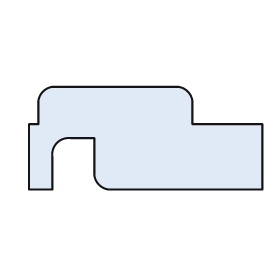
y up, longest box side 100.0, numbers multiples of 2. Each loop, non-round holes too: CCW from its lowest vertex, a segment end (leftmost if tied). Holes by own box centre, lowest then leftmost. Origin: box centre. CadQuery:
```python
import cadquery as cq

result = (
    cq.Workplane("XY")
    .moveTo(-50.0, -22.0)
    .lineTo(-40.0, -22.0)
    .lineTo(-40.0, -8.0)
    .threePointArc((-38.0, -2.0), (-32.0, 0.0))
    .lineTo(-22.0, 0.0)
    .lineTo(-22.0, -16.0)
    .threePointArc((-20.0, -20.0), (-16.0, -22.0))
    .lineTo(50.0, -22.0)
    .lineTo(50.0, 6.0)
    .lineTo(20.0, 6.0)
    .lineTo(20.0, 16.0)
    .threePointArc((18.0, 20.0), (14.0, 22.0))
    .lineTo(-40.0, 22.0)
    .threePointArc((-44.0, 20.0), (-46.0, 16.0))
    .lineTo(-46.0, 6.0)
    .lineTo(-50.0, 6.0)
    .close()
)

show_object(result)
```